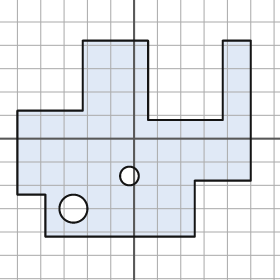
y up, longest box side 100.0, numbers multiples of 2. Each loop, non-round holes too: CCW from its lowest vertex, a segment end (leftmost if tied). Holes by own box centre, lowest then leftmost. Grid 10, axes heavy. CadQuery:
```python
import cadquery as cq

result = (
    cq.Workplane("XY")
    .moveTo(-38.0, -42.0)
    .lineTo(26.0, -42.0)
    .lineTo(26.0, -18.0)
    .lineTo(50.0, -18.0)
    .lineTo(50.0, 42.0)
    .lineTo(38.0, 42.0)
    .lineTo(38.0, 8.0)
    .lineTo(6.0, 8.0)
    .lineTo(6.0, 42.0)
    .lineTo(-22.0, 42.0)
    .lineTo(-22.0, 12.0)
    .lineTo(-50.0, 12.0)
    .lineTo(-50.0, -24.0)
    .lineTo(-38.0, -24.0)
    .close()
    .moveTo(-26.0, -30.0)
    .circle(6.0)
    .moveTo(-2.0, -16.0)
    .circle(4.0)
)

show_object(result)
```